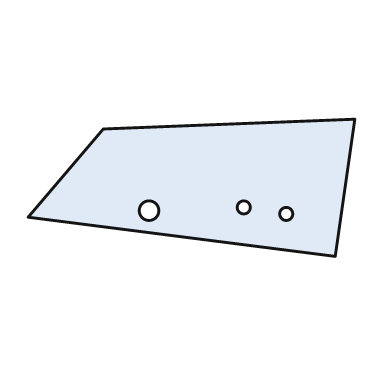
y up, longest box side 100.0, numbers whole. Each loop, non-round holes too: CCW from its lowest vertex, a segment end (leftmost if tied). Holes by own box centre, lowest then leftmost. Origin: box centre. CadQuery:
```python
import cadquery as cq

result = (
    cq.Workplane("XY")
    .moveTo(44.0, -21.0)
    .lineTo(50.0, 21.0)
    .lineTo(-27.0, 18.0)
    .lineTo(-50.0, -9.0)
    .close()
    .moveTo(29.0, -8.0)
    .circle(2.0)
    .moveTo(-13.0, -7.0)
    .circle(3.0)
    .moveTo(16.0, -6.0)
    .circle(2.0)
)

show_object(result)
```